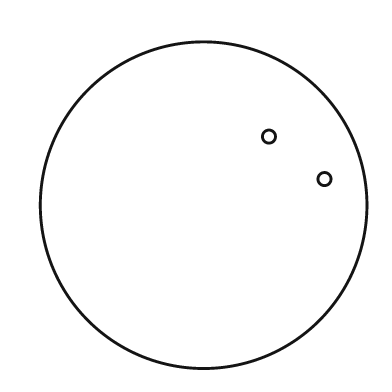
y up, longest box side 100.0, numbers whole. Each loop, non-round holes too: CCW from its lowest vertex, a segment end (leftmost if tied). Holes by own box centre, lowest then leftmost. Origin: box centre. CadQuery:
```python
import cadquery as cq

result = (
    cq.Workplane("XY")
    .moveTo(0.0, 0.0)
    .circle(50.0)
    .moveTo(37.0, 8.0)
    .circle(2.0)
    .moveTo(20.0, 21.0)
    .circle(2.0)
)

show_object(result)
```